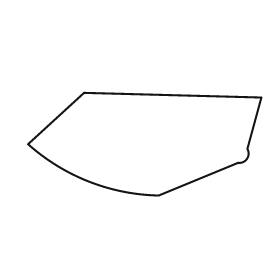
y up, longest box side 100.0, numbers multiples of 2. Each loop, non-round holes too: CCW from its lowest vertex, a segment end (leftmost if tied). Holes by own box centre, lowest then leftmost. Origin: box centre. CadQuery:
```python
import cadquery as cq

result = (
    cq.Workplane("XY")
    .moveTo(6.0, -22.0)
    .lineTo(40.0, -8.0)
    .threePointArc((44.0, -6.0), (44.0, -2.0))
    .lineTo(50.0, 20.0)
    .lineTo(-26.0, 22.0)
    .lineTo(-50.0, 0.0)
    .threePointArc((-24.0, -16.0), (6.0, -22.0))
    .close()
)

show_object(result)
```